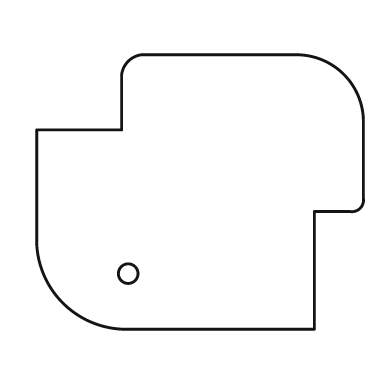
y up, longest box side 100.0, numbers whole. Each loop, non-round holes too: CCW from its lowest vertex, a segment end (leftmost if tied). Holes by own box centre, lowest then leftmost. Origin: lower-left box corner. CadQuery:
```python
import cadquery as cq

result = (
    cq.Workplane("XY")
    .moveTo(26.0, 0.0)
    .lineTo(85.0, 0.0)
    .lineTo(85.0, 36.0)
    .lineTo(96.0, 36.0)
    .threePointArc((99.0, 37.0), (100.0, 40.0))
    .lineTo(100.0, 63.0)
    .threePointArc((94.0, 78.0), (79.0, 84.0))
    .lineTo(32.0, 84.0)
    .threePointArc((28.0, 82.0), (26.0, 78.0))
    .lineTo(26.0, 61.0)
    .lineTo(0.0, 61.0)
    .lineTo(0.0, 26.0)
    .threePointArc((8.0, 8.0), (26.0, 0.0))
    .close()
    .moveTo(28.0, 17.0)
    .circle(3.0)
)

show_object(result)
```